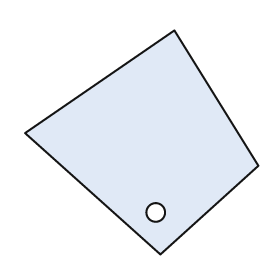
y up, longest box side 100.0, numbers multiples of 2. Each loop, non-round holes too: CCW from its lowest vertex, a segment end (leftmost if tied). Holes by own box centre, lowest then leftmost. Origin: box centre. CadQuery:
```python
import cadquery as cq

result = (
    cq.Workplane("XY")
    .moveTo(8.0, -48.0)
    .lineTo(50.0, -10.0)
    .lineTo(14.0, 48.0)
    .lineTo(-50.0, 4.0)
    .close()
    .moveTo(6.0, -30.0)
    .circle(4.0)
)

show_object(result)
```